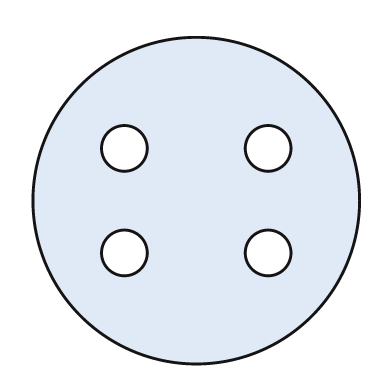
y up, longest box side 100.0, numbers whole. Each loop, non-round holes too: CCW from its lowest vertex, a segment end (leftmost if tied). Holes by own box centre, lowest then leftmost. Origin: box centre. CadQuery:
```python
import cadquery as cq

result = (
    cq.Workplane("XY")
    .moveTo(0.0, 0.0)
    .circle(50.0)
    .moveTo(-22.0, -16.0)
    .circle(7.0)
    .moveTo(22.0, -16.0)
    .circle(7.0)
    .moveTo(-22.0, 16.0)
    .circle(7.0)
    .moveTo(22.0, 16.0)
    .circle(7.0)
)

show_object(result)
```